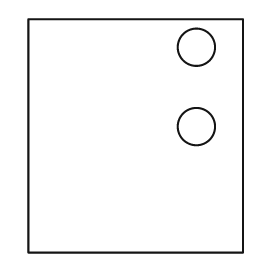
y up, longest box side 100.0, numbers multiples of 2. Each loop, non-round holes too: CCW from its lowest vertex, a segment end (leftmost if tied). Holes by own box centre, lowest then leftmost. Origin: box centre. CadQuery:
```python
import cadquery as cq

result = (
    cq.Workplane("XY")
    .moveTo(-46.0, -50.0)
    .lineTo(46.0, -50.0)
    .lineTo(46.0, 50.0)
    .lineTo(-46.0, 50.0)
    .close()
    .moveTo(26.0, 4.0)
    .circle(8.0)
    .moveTo(26.0, 38.0)
    .circle(8.0)
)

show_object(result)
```